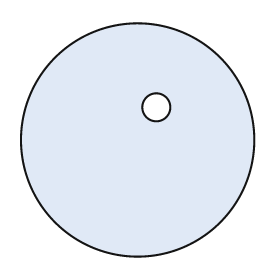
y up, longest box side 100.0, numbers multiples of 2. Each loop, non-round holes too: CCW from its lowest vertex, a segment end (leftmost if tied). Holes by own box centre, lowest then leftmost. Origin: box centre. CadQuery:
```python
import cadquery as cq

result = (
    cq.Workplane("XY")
    .moveTo(0.0, 0.0)
    .circle(50.0)
    .moveTo(8.0, 14.0)
    .circle(6.0)
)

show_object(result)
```